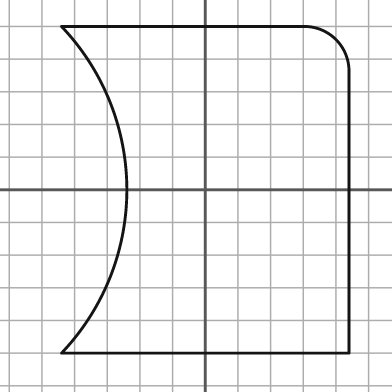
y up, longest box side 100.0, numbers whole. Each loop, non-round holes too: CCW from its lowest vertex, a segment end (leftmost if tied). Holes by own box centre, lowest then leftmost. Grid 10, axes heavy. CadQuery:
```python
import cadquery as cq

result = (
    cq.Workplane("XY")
    .moveTo(-44.0, -50.0)
    .lineTo(44.0, -50.0)
    .lineTo(44.0, 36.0)
    .threePointArc((40.0, 46.0), (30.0, 50.0))
    .lineTo(-44.0, 50.0)
    .threePointArc((-24.0, 0.0), (-44.0, -50.0))
    .close()
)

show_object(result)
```